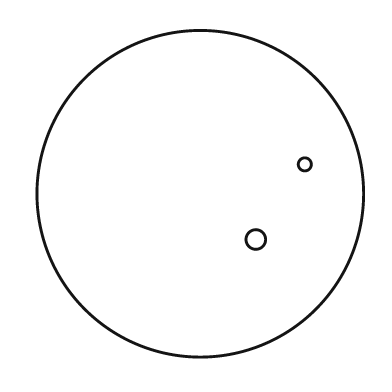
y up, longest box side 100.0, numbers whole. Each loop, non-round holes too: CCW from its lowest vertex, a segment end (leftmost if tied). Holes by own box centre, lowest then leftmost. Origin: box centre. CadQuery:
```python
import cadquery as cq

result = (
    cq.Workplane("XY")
    .moveTo(0.0, 0.0)
    .circle(50.0)
    .moveTo(17.0, -14.0)
    .circle(3.0)
    .moveTo(32.0, 9.0)
    .circle(2.0)
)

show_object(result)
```